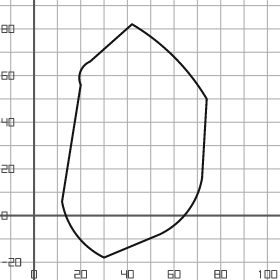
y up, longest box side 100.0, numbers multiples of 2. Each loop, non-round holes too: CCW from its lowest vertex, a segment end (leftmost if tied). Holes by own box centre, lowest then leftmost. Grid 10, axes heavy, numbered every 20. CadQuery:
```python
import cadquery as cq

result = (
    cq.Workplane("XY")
    .moveTo(30.0, -18.0)
    .lineTo(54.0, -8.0)
    .threePointArc((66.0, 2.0), (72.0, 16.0))
    .lineTo(74.0, 50.0)
    .threePointArc((60.0, 68.0), (42.0, 82.0))
    .lineTo(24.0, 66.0)
    .threePointArc((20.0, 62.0), (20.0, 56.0))
    .lineTo(12.0, 6.0)
    .threePointArc((18.0, -8.0), (30.0, -18.0))
    .close()
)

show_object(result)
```